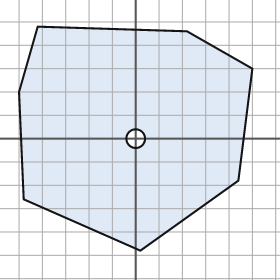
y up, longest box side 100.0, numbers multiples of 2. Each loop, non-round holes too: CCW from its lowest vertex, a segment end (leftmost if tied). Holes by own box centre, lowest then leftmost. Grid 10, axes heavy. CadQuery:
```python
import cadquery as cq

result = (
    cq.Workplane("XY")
    .moveTo(2.0, -48.0)
    .lineTo(44.0, -18.0)
    .lineTo(50.0, 30.0)
    .lineTo(22.0, 46.0)
    .lineTo(-42.0, 48.0)
    .lineTo(-50.0, 20.0)
    .lineTo(-48.0, -26.0)
    .close()
    .moveTo(0.0, 0.0)
    .circle(4.0)
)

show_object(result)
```